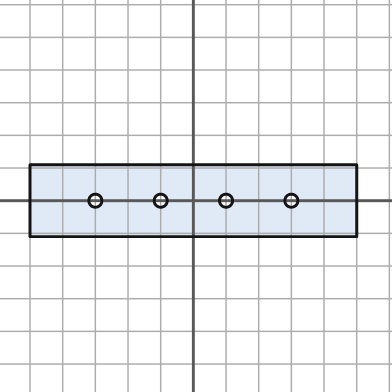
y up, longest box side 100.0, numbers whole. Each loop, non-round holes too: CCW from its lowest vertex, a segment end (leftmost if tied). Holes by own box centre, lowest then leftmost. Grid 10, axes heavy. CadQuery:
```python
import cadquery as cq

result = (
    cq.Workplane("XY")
    .moveTo(-50.0, -11.0)
    .lineTo(50.0, -11.0)
    .lineTo(50.0, 11.0)
    .lineTo(-50.0, 11.0)
    .close()
    .moveTo(-30.0, 0.0)
    .circle(2.0)
    .moveTo(-10.0, 0.0)
    .circle(2.0)
    .moveTo(10.0, 0.0)
    .circle(2.0)
    .moveTo(30.0, 0.0)
    .circle(2.0)
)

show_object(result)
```